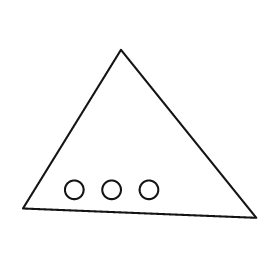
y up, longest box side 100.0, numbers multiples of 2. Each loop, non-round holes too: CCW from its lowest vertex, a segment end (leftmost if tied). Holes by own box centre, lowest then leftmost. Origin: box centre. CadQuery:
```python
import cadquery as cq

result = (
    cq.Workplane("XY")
    .moveTo(50.0, -36.0)
    .lineTo(-8.0, 36.0)
    .lineTo(-50.0, -32.0)
    .close()
    .moveTo(-28.0, -24.0)
    .circle(4.0)
    .moveTo(-12.0, -24.0)
    .circle(4.0)
    .moveTo(4.0, -24.0)
    .circle(4.0)
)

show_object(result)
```